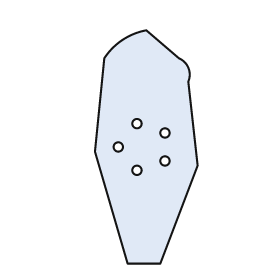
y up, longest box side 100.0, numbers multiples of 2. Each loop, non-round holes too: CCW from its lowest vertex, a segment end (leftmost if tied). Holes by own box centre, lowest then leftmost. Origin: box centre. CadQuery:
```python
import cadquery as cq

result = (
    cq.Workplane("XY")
    .moveTo(-8.0, -50.0)
    .lineTo(6.0, -50.0)
    .lineTo(22.0, -8.0)
    .lineTo(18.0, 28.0)
    .threePointArc((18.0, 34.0), (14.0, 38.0))
    .lineTo(0.0, 50.0)
    .threePointArc((-10.0, 46.0), (-18.0, 38.0))
    .lineTo(-22.0, -2.0)
    .close()
    .moveTo(-4.0, -10.0)
    .circle(2.0)
    .moveTo(8.0, -6.0)
    .circle(2.0)
    .moveTo(-12.0, 0.0)
    .circle(2.0)
    .moveTo(8.0, 6.0)
    .circle(2.0)
    .moveTo(-4.0, 10.0)
    .circle(2.0)
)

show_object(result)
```